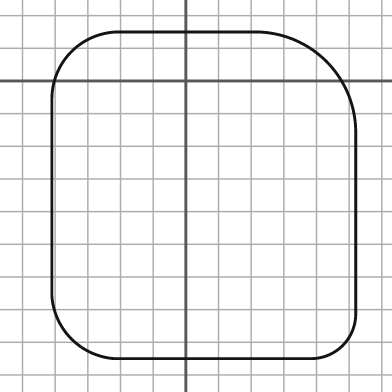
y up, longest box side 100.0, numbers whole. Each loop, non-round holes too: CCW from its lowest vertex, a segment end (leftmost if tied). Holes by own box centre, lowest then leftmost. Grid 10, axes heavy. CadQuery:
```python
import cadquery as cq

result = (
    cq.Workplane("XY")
    .moveTo(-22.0, -85.0)
    .lineTo(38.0, -85.0)
    .threePointArc((48.0, -81.0), (52.0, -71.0))
    .lineTo(52.0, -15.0)
    .threePointArc((43.0, 6.0), (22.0, 15.0))
    .lineTo(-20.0, 15.0)
    .threePointArc((-35.0, 9.0), (-41.0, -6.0))
    .lineTo(-41.0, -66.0)
    .threePointArc((-35.0, -79.0), (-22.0, -85.0))
    .close()
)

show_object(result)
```